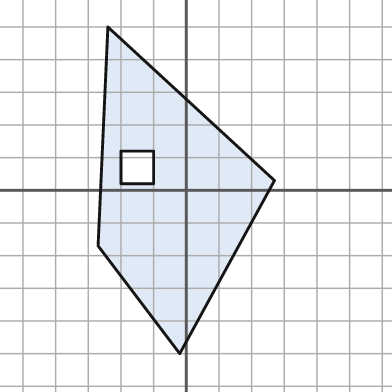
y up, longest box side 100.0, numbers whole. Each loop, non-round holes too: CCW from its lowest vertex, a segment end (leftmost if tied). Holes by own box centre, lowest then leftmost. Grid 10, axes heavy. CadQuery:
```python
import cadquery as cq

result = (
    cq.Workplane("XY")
    .moveTo(-2.0, -50.0)
    .lineTo(27.0, 3.0)
    .lineTo(-24.0, 50.0)
    .lineTo(-27.0, -17.0)
    .close()
    .moveTo(-20.0, 2.0)
    .lineTo(-10.0, 2.0)
    .lineTo(-10.0, 12.0)
    .lineTo(-20.0, 12.0)
    .close()
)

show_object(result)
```